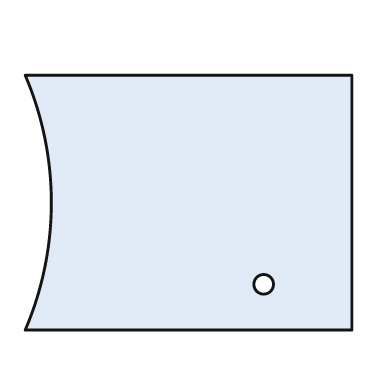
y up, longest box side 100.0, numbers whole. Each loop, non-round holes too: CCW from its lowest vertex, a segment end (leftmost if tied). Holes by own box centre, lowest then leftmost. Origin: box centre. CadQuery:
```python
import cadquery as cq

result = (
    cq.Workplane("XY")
    .moveTo(-50.0, -39.0)
    .lineTo(50.0, -39.0)
    .lineTo(50.0, 39.0)
    .lineTo(-50.0, 39.0)
    .threePointArc((-42.0, 0.0), (-50.0, -39.0))
    .close()
    .moveTo(23.0, -25.0)
    .circle(3.0)
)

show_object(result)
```